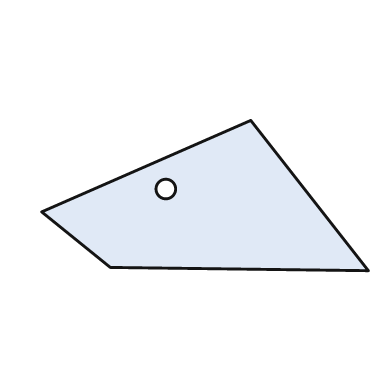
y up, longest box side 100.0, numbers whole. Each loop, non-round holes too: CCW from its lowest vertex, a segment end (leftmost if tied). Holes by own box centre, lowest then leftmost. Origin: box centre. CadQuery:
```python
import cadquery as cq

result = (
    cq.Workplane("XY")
    .moveTo(50.0, -23.0)
    .lineTo(14.0, 23.0)
    .lineTo(-50.0, -5.0)
    .lineTo(-29.0, -22.0)
    .close()
    .moveTo(-12.0, 2.0)
    .circle(3.0)
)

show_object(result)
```